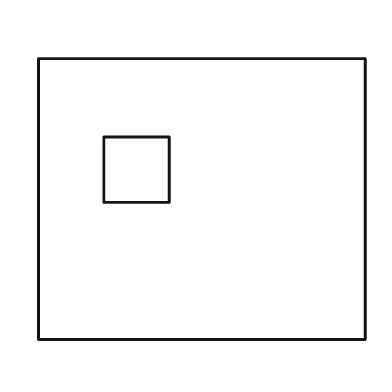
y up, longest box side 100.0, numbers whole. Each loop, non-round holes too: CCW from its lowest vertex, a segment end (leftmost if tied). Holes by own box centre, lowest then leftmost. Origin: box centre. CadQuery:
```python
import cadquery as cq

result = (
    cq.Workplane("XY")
    .moveTo(-50.0, -43.0)
    .lineTo(50.0, -43.0)
    .lineTo(50.0, 43.0)
    .lineTo(-50.0, 43.0)
    .close()
    .moveTo(-30.0, -1.0)
    .lineTo(-10.0, -1.0)
    .lineTo(-10.0, 19.0)
    .lineTo(-30.0, 19.0)
    .close()
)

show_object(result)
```